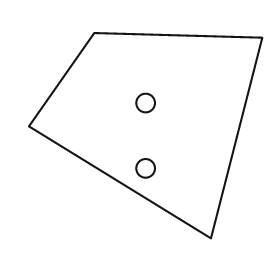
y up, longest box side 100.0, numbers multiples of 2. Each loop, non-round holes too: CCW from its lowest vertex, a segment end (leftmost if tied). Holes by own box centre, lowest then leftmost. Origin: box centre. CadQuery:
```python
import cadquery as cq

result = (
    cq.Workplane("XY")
    .moveTo(28.0, -44.0)
    .lineTo(50.0, 42.0)
    .lineTo(-22.0, 44.0)
    .lineTo(-50.0, 4.0)
    .close()
    .moveTo(0.0, -14.0)
    .circle(4.0)
    .moveTo(0.0, 14.0)
    .circle(4.0)
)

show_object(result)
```